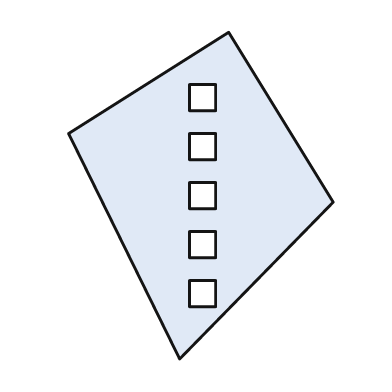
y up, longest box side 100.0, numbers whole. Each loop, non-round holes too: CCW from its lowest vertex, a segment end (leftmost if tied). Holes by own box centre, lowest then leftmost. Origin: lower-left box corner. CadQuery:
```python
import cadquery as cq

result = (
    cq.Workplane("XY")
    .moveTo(34.0, 0.0)
    .lineTo(81.0, 48.0)
    .lineTo(49.0, 100.0)
    .lineTo(0.0, 69.0)
    .close()
    .moveTo(37.0, 16.0)
    .lineTo(45.0, 16.0)
    .lineTo(45.0, 24.0)
    .lineTo(37.0, 24.0)
    .close()
    .moveTo(37.0, 31.0)
    .lineTo(45.0, 31.0)
    .lineTo(45.0, 39.0)
    .lineTo(37.0, 39.0)
    .close()
    .moveTo(37.0, 46.0)
    .lineTo(45.0, 46.0)
    .lineTo(45.0, 54.0)
    .lineTo(37.0, 54.0)
    .close()
    .moveTo(37.0, 61.0)
    .lineTo(45.0, 61.0)
    .lineTo(45.0, 69.0)
    .lineTo(37.0, 69.0)
    .close()
    .moveTo(37.0, 76.0)
    .lineTo(45.0, 76.0)
    .lineTo(45.0, 84.0)
    .lineTo(37.0, 84.0)
    .close()
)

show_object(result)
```